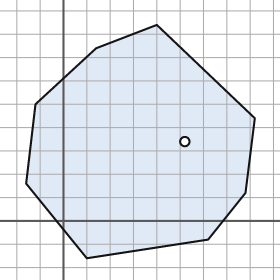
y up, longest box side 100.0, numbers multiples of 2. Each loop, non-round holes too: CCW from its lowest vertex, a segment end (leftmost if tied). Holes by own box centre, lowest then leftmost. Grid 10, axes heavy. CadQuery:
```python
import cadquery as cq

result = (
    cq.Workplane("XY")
    .moveTo(10.0, -16.0)
    .lineTo(62.0, -8.0)
    .lineTo(78.0, 12.0)
    .lineTo(82.0, 44.0)
    .lineTo(40.0, 84.0)
    .lineTo(14.0, 74.0)
    .lineTo(-12.0, 50.0)
    .lineTo(-16.0, 16.0)
    .close()
    .moveTo(52.0, 34.0)
    .circle(2.0)
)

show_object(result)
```